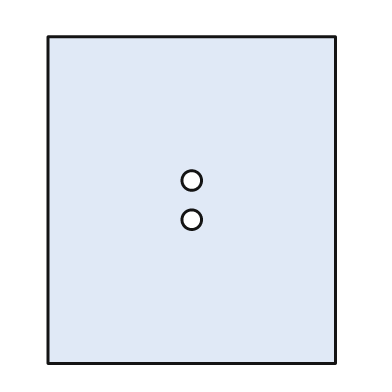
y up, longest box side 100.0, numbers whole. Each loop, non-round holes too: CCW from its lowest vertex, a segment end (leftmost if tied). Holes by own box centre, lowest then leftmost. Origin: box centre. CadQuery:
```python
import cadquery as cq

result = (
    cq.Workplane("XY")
    .moveTo(-44.0, -50.0)
    .lineTo(44.0, -50.0)
    .lineTo(44.0, 50.0)
    .lineTo(-44.0, 50.0)
    .close()
    .moveTo(0.0, -6.0)
    .circle(3.0)
    .moveTo(0.0, 6.0)
    .circle(3.0)
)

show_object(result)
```